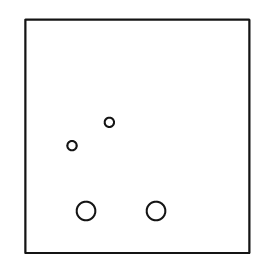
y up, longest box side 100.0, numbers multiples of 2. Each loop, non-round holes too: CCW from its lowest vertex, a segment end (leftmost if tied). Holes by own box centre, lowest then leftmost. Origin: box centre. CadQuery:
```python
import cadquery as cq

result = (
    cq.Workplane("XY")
    .moveTo(-48.0, -50.0)
    .lineTo(48.0, -50.0)
    .lineTo(48.0, 50.0)
    .lineTo(-48.0, 50.0)
    .close()
    .moveTo(-22.0, -32.0)
    .circle(4.0)
    .moveTo(8.0, -32.0)
    .circle(4.0)
    .moveTo(-28.0, -4.0)
    .circle(2.0)
    .moveTo(-12.0, 6.0)
    .circle(2.0)
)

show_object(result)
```